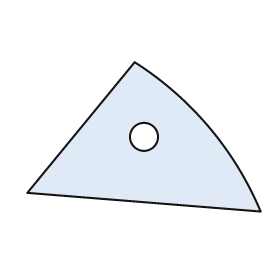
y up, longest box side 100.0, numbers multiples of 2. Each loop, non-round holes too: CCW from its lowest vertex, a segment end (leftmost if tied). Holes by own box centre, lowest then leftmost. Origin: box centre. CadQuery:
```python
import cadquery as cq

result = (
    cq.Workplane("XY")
    .moveTo(50.0, -32.0)
    .threePointArc((28.0, 4.0), (-4.0, 32.0))
    .lineTo(-50.0, -24.0)
    .close()
    .moveTo(0.0, 0.0)
    .circle(6.0)
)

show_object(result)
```